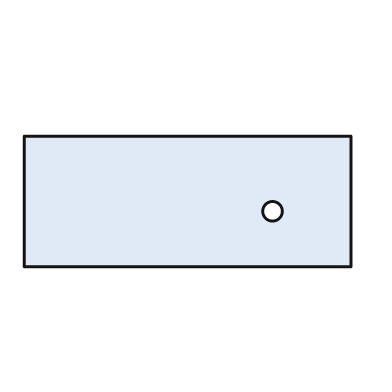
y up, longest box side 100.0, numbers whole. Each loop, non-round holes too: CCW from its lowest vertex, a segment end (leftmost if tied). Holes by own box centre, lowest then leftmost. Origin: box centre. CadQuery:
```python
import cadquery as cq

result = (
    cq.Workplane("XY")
    .moveTo(-50.0, -20.0)
    .lineTo(50.0, -20.0)
    .lineTo(50.0, 20.0)
    .lineTo(-50.0, 20.0)
    .close()
    .moveTo(26.0, -3.0)
    .circle(3.0)
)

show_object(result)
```